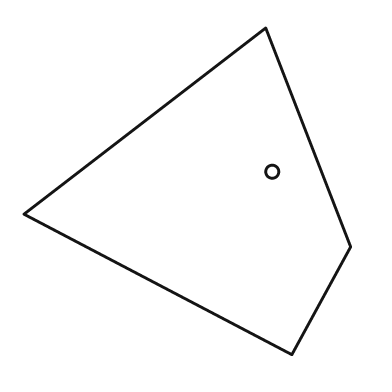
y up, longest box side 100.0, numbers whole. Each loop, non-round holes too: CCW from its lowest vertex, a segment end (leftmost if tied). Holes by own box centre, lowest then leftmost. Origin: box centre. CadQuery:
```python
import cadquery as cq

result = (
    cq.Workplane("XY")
    .moveTo(32.0, -50.0)
    .lineTo(50.0, -17.0)
    .lineTo(24.0, 50.0)
    .lineTo(-50.0, -7.0)
    .close()
    .moveTo(26.0, 6.0)
    .circle(2.0)
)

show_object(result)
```